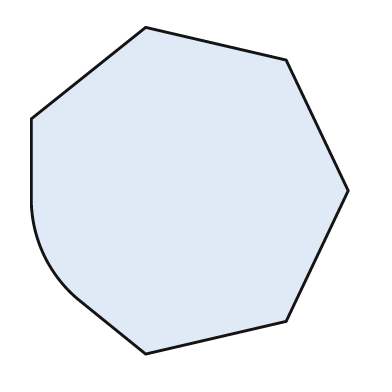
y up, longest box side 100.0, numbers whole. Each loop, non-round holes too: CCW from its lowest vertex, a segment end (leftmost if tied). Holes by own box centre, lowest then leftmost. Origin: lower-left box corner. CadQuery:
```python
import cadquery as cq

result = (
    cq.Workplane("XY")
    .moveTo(35.0, 0.0)
    .lineTo(78.0, 10.0)
    .lineTo(97.0, 50.0)
    .lineTo(78.0, 90.0)
    .lineTo(35.0, 100.0)
    .lineTo(0.0, 72.0)
    .lineTo(0.0, 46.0)
    .threePointArc((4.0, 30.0), (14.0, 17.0))
    .close()
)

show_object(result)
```